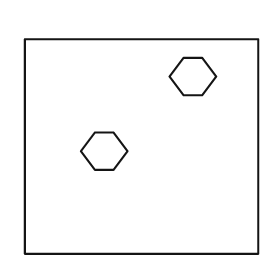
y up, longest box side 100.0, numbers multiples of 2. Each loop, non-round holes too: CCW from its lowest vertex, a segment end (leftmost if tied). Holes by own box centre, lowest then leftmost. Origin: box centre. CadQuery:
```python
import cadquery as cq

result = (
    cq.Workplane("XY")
    .moveTo(-50.0, -46.0)
    .lineTo(50.0, -46.0)
    .lineTo(50.0, 46.0)
    .lineTo(-50.0, 46.0)
    .close()
    .moveTo(-20.0, -10.0)
    .lineTo(-12.0, -10.0)
    .lineTo(-6.0, -2.0)
    .lineTo(-12.0, 6.0)
    .lineTo(-20.0, 6.0)
    .lineTo(-26.0, -2.0)
    .close()
    .moveTo(18.0, 22.0)
    .lineTo(26.0, 22.0)
    .lineTo(32.0, 30.0)
    .lineTo(26.0, 38.0)
    .lineTo(18.0, 38.0)
    .lineTo(12.0, 30.0)
    .close()
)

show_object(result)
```